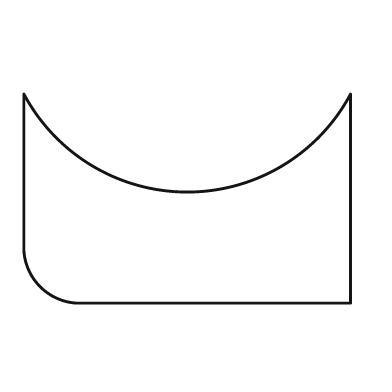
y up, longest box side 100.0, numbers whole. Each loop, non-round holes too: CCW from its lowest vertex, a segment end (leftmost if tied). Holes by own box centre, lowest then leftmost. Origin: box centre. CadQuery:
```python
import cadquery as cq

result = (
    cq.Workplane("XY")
    .moveTo(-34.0, -32.0)
    .lineTo(50.0, -32.0)
    .lineTo(50.0, 32.0)
    .threePointArc((0.0, 2.0), (-50.0, 32.0))
    .lineTo(-50.0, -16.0)
    .threePointArc((-45.0, -27.0), (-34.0, -32.0))
    .close()
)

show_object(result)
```